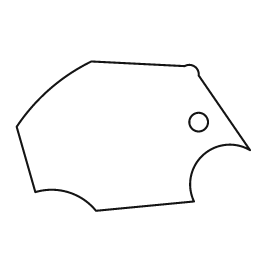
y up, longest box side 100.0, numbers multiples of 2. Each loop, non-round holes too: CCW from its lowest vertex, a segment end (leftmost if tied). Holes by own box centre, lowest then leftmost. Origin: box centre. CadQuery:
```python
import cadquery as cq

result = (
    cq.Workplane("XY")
    .moveTo(-16.0, -32.0)
    .lineTo(26.0, -28.0)
    .threePointArc((30.0, -8.0), (50.0, -6.0))
    .lineTo(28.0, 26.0)
    .threePointArc((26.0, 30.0), (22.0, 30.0))
    .lineTo(-18.0, 32.0)
    .threePointArc((-36.0, 20.0), (-50.0, 4.0))
    .lineTo(-42.0, -24.0)
    .threePointArc((-28.0, -24.0), (-16.0, -32.0))
    .close()
    .moveTo(28.0, 6.0)
    .circle(4.0)
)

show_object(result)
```